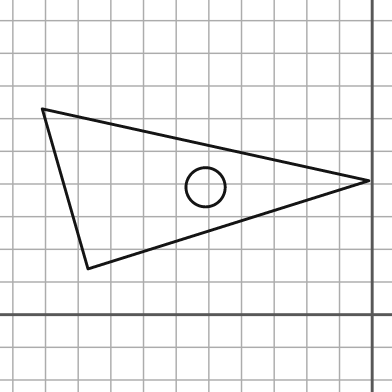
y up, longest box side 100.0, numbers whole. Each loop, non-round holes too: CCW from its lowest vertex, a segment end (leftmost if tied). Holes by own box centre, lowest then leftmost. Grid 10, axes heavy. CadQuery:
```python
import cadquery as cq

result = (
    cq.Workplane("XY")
    .moveTo(-87.0, 14.0)
    .lineTo(-1.0, 41.0)
    .lineTo(-101.0, 63.0)
    .close()
    .moveTo(-51.0, 39.0)
    .circle(6.0)
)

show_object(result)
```